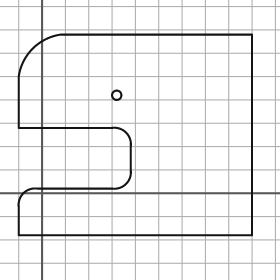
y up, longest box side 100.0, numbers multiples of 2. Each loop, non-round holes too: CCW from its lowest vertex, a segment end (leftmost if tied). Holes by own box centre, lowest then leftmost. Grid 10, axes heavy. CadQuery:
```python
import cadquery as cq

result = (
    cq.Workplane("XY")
    .moveTo(-10.0, -18.0)
    .lineTo(90.0, -18.0)
    .lineTo(90.0, 68.0)
    .lineTo(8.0, 68.0)
    .threePointArc((-4.0, 62.0), (-10.0, 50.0))
    .lineTo(-10.0, 28.0)
    .lineTo(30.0, 28.0)
    .threePointArc((36.0, 26.0), (38.0, 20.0))
    .lineTo(38.0, 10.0)
    .threePointArc((36.0, 4.0), (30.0, 2.0))
    .lineTo(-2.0, 2.0)
    .threePointArc((-8.0, 0.0), (-10.0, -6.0))
    .close()
    .moveTo(32.0, 42.0)
    .circle(2.0)
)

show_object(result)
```